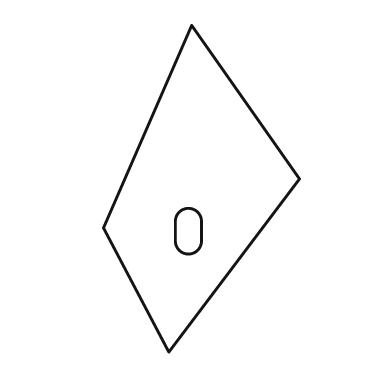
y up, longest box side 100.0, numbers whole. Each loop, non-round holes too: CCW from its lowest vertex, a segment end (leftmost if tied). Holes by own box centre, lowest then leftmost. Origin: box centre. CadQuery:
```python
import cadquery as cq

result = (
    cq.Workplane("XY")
    .moveTo(-10.0, -50.0)
    .lineTo(30.0, 3.0)
    .lineTo(-3.0, 50.0)
    .lineTo(-30.0, -12.0)
    .close()
    .moveTo(-8.0, -16.0)
    .threePointArc((-4.0, -20.0), (0.0, -16.0))
    .lineTo(0.0, -10.0)
    .threePointArc((-4.0, -6.0), (-8.0, -10.0))
    .close()
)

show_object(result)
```